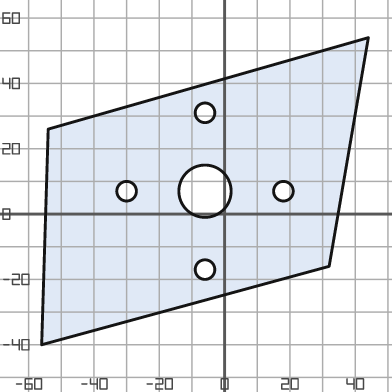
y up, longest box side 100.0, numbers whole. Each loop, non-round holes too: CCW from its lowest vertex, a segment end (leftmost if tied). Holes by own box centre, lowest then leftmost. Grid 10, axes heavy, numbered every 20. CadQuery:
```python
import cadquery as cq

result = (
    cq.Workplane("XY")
    .moveTo(-56.0, -40.0)
    .lineTo(32.0, -16.0)
    .lineTo(44.0, 54.0)
    .lineTo(-54.0, 26.0)
    .close()
    .moveTo(-6.0, -17.0)
    .circle(3.0)
    .moveTo(-30.0, 7.0)
    .circle(3.0)
    .moveTo(-6.0, 7.0)
    .circle(8.0)
    .moveTo(18.0, 7.0)
    .circle(3.0)
    .moveTo(-6.0, 31.0)
    .circle(3.0)
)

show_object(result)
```